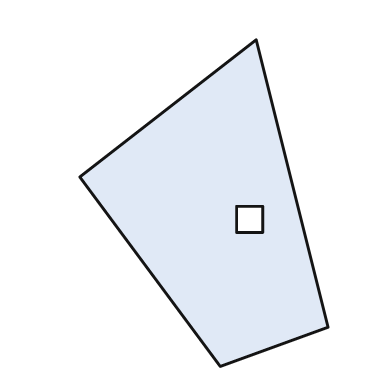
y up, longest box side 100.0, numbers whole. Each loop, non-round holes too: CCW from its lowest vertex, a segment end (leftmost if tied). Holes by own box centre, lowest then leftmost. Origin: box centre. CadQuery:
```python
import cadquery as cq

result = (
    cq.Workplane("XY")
    .moveTo(5.0, -50.0)
    .lineTo(38.0, -38.0)
    .lineTo(16.0, 50.0)
    .lineTo(-38.0, 8.0)
    .close()
    .moveTo(10.0, -9.0)
    .lineTo(18.0, -9.0)
    .lineTo(18.0, -1.0)
    .lineTo(10.0, -1.0)
    .close()
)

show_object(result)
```